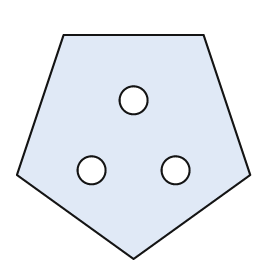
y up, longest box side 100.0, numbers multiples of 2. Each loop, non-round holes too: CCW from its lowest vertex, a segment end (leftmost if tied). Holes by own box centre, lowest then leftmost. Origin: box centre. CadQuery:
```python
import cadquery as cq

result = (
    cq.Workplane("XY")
    .moveTo(0.0, -48.0)
    .lineTo(50.0, -12.0)
    .lineTo(30.0, 48.0)
    .lineTo(-30.0, 48.0)
    .lineTo(-50.0, -12.0)
    .close()
    .moveTo(-18.0, -10.0)
    .circle(6.0)
    .moveTo(18.0, -10.0)
    .circle(6.0)
    .moveTo(0.0, 20.0)
    .circle(6.0)
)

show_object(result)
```